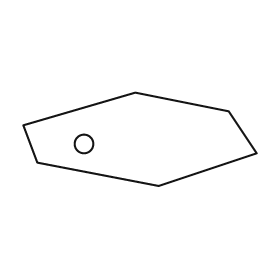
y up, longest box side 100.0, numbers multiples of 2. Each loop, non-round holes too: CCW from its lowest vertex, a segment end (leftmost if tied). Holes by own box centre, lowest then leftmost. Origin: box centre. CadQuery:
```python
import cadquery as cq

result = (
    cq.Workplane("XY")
    .moveTo(8.0, -20.0)
    .lineTo(50.0, -6.0)
    .lineTo(38.0, 12.0)
    .lineTo(-2.0, 20.0)
    .lineTo(-50.0, 6.0)
    .lineTo(-44.0, -10.0)
    .close()
    .moveTo(-24.0, -2.0)
    .circle(4.0)
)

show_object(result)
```